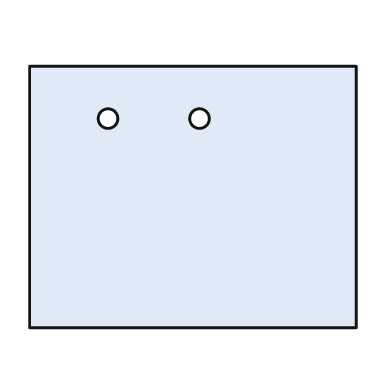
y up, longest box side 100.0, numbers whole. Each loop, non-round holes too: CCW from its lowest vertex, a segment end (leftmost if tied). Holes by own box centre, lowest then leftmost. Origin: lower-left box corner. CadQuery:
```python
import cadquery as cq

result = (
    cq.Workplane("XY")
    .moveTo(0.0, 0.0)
    .lineTo(100.0, 0.0)
    .lineTo(100.0, 80.0)
    .lineTo(0.0, 80.0)
    .close()
    .moveTo(24.0, 64.0)
    .circle(3.0)
    .moveTo(52.0, 64.0)
    .circle(3.0)
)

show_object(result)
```